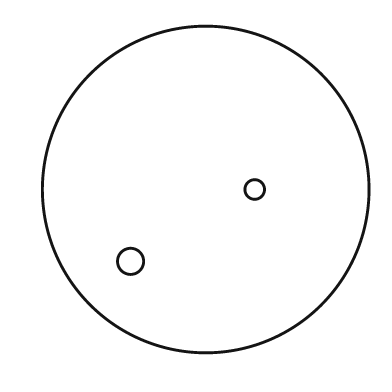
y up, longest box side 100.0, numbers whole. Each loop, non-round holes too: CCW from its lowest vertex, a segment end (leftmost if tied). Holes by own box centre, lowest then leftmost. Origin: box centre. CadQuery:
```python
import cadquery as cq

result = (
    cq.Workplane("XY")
    .moveTo(0.0, 0.0)
    .circle(50.0)
    .moveTo(-23.0, -22.0)
    .circle(4.0)
    .moveTo(15.0, 0.0)
    .circle(3.0)
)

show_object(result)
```